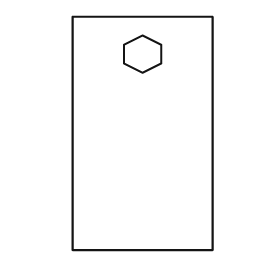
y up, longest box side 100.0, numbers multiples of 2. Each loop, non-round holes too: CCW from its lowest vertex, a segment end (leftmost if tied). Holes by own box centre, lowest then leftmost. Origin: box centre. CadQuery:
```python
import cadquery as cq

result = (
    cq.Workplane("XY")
    .moveTo(-30.0, -50.0)
    .lineTo(30.0, -50.0)
    .lineTo(30.0, 50.0)
    .lineTo(-30.0, 50.0)
    .close()
    .moveTo(0.0, 26.0)
    .lineTo(8.0, 30.0)
    .lineTo(8.0, 38.0)
    .lineTo(0.0, 42.0)
    .lineTo(-8.0, 38.0)
    .lineTo(-8.0, 30.0)
    .close()
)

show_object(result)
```